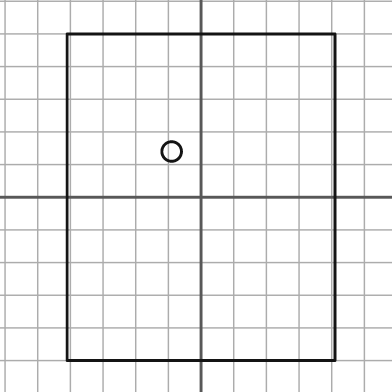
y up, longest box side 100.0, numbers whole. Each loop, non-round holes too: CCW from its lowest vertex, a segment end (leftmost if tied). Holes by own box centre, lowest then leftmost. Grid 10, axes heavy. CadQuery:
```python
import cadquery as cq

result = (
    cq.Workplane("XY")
    .moveTo(-41.0, -50.0)
    .lineTo(41.0, -50.0)
    .lineTo(41.0, 50.0)
    .lineTo(-41.0, 50.0)
    .close()
    .moveTo(-9.0, 14.0)
    .circle(3.0)
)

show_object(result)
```